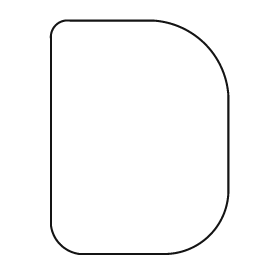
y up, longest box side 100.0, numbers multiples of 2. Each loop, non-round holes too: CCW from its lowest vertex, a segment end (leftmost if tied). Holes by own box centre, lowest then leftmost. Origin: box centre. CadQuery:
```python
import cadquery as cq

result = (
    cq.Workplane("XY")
    .moveTo(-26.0, -50.0)
    .lineTo(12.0, -50.0)
    .threePointArc((30.0, -42.0), (38.0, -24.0))
    .lineTo(38.0, 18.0)
    .threePointArc((28.0, 40.0), (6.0, 50.0))
    .lineTo(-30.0, 50.0)
    .threePointArc((-36.0, 48.0), (-38.0, 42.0))
    .lineTo(-38.0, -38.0)
    .threePointArc((-34.0, -46.0), (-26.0, -50.0))
    .close()
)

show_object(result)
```